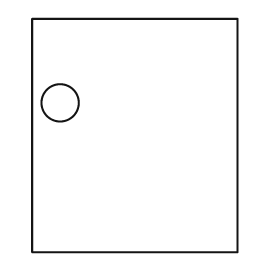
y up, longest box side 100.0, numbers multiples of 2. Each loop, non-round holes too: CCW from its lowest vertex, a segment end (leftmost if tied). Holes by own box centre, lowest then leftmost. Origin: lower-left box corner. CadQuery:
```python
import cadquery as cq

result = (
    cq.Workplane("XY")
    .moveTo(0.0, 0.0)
    .lineTo(88.0, 0.0)
    .lineTo(88.0, 100.0)
    .lineTo(0.0, 100.0)
    .close()
    .moveTo(12.0, 64.0)
    .circle(8.0)
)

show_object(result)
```